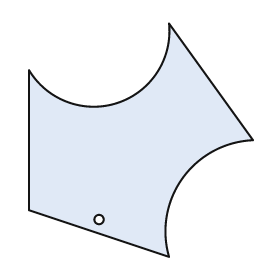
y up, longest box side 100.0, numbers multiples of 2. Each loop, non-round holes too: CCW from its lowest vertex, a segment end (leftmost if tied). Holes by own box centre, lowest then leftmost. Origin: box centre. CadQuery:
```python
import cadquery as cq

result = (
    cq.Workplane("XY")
    .moveTo(12.0, -50.0)
    .threePointArc((18.0, -16.0), (48.0, 0.0))
    .lineTo(12.0, 50.0)
    .threePointArc((-10.0, 16.0), (-48.0, 30.0))
    .lineTo(-48.0, -30.0)
    .close()
    .moveTo(-18.0, -34.0)
    .circle(2.0)
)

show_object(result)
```